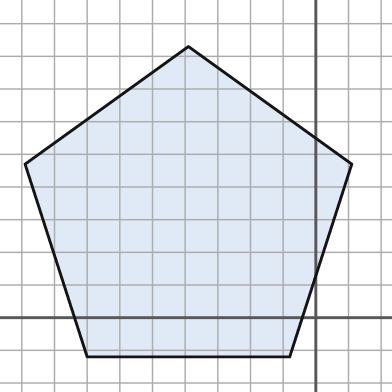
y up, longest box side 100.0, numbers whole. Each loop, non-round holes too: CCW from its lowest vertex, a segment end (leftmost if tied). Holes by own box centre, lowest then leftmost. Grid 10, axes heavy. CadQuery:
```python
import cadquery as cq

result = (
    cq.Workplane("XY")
    .moveTo(-70.0, -12.0)
    .lineTo(-8.0, -12.0)
    .lineTo(11.0, 47.0)
    .lineTo(-39.0, 83.0)
    .lineTo(-89.0, 47.0)
    .close()
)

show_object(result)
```